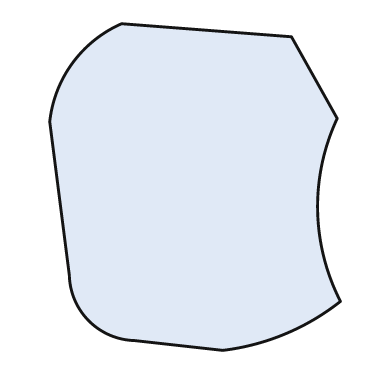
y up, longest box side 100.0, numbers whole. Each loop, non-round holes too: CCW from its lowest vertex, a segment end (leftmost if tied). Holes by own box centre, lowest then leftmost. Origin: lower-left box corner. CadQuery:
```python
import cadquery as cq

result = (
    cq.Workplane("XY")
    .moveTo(53.0, 0.0)
    .threePointArc((72.0, 5.0), (89.0, 15.0))
    .threePointArc((82.0, 43.0), (88.0, 71.0))
    .lineTo(74.0, 96.0)
    .lineTo(22.0, 100.0)
    .threePointArc((7.0, 88.0), (0.0, 70.0))
    .lineTo(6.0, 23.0)
    .threePointArc((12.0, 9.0), (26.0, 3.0))
    .close()
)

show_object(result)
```